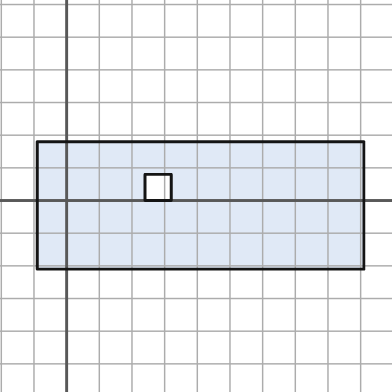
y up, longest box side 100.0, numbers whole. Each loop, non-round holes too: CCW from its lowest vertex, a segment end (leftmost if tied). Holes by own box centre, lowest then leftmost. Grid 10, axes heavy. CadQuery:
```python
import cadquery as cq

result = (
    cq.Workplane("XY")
    .moveTo(-9.0, -21.0)
    .lineTo(91.0, -21.0)
    .lineTo(91.0, 18.0)
    .lineTo(-9.0, 18.0)
    .close()
    .moveTo(24.0, 0.0)
    .lineTo(32.0, 0.0)
    .lineTo(32.0, 8.0)
    .lineTo(24.0, 8.0)
    .close()
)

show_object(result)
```